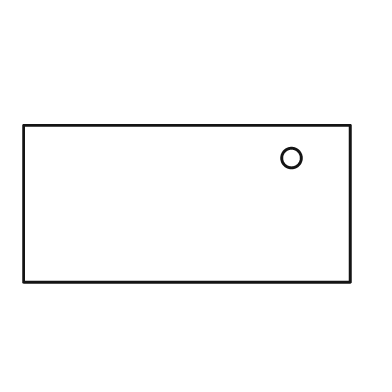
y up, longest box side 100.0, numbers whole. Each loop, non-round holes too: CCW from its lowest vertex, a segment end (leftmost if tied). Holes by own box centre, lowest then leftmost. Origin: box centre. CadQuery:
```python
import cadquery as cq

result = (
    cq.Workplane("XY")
    .moveTo(-50.0, -24.0)
    .lineTo(50.0, -24.0)
    .lineTo(50.0, 24.0)
    .lineTo(-50.0, 24.0)
    .close()
    .moveTo(32.0, 14.0)
    .circle(3.0)
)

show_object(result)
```